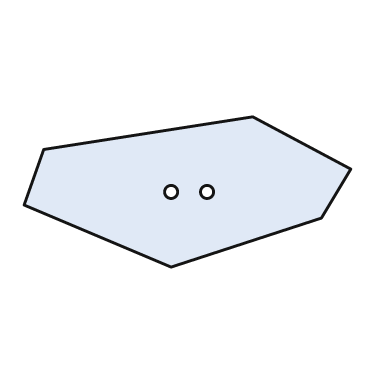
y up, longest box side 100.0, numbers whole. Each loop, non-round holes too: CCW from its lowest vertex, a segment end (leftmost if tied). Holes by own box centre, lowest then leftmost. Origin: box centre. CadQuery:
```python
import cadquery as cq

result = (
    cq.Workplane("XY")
    .moveTo(-5.0, -23.0)
    .lineTo(41.0, -8.0)
    .lineTo(50.0, 7.0)
    .lineTo(20.0, 23.0)
    .lineTo(-44.0, 13.0)
    .lineTo(-50.0, -4.0)
    .close()
    .moveTo(-5.0, 0.0)
    .circle(2.0)
    .moveTo(6.0, 0.0)
    .circle(2.0)
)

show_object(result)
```